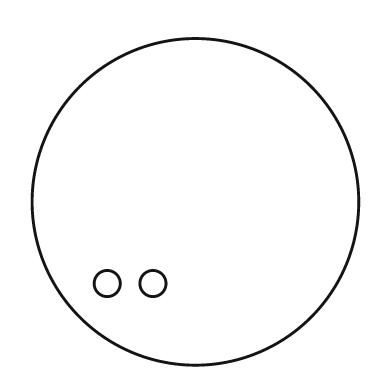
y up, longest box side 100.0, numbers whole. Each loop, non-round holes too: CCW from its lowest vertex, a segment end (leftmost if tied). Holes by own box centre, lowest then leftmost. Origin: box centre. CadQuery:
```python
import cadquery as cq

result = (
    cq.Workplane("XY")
    .moveTo(0.0, 0.0)
    .circle(50.0)
    .moveTo(-27.0, -25.0)
    .circle(4.0)
    .moveTo(-13.0, -25.0)
    .circle(4.0)
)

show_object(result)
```